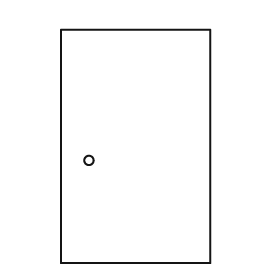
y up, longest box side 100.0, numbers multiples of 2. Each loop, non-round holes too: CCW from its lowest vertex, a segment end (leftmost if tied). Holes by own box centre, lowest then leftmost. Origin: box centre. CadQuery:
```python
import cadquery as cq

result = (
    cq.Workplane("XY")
    .moveTo(-32.0, -50.0)
    .lineTo(32.0, -50.0)
    .lineTo(32.0, 50.0)
    .lineTo(-32.0, 50.0)
    .close()
    .moveTo(-20.0, -6.0)
    .circle(2.0)
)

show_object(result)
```